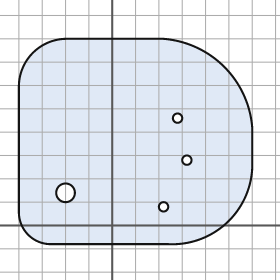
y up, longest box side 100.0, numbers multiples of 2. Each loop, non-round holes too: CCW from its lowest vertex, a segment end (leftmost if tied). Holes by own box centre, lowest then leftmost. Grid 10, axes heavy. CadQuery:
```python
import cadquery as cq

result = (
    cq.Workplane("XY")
    .moveTo(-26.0, -8.0)
    .lineTo(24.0, -8.0)
    .threePointArc((50.0, 2.0), (60.0, 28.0))
    .lineTo(60.0, 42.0)
    .threePointArc((48.0, 68.0), (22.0, 80.0))
    .lineTo(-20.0, 80.0)
    .threePointArc((-34.0, 74.0), (-40.0, 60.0))
    .lineTo(-40.0, 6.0)
    .threePointArc((-36.0, -4.0), (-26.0, -8.0))
    .close()
    .moveTo(22.0, 8.0)
    .circle(2.0)
    .moveTo(-20.0, 14.0)
    .circle(4.0)
    .moveTo(32.0, 28.0)
    .circle(2.0)
    .moveTo(28.0, 46.0)
    .circle(2.0)
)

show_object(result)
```